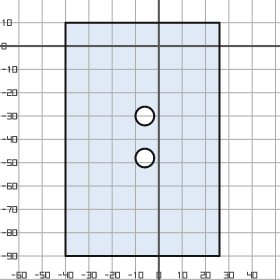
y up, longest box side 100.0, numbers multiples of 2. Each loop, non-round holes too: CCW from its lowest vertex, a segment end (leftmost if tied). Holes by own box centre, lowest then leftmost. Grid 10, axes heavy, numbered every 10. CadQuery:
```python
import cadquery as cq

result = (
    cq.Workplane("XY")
    .moveTo(-40.0, -90.0)
    .lineTo(26.0, -90.0)
    .lineTo(26.0, 10.0)
    .lineTo(-40.0, 10.0)
    .close()
    .moveTo(-6.0, -48.0)
    .circle(4.0)
    .moveTo(-6.0, -30.0)
    .circle(4.0)
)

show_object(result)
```